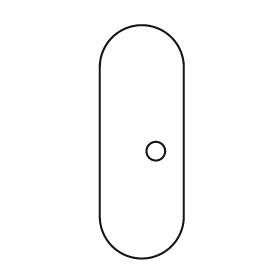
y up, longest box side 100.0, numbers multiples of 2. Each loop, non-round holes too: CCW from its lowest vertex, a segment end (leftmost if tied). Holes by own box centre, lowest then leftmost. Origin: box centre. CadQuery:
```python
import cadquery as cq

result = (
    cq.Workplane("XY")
    .moveTo(-18.0, -32.0)
    .threePointArc((0.0, -50.0), (18.0, -32.0))
    .lineTo(18.0, 32.0)
    .threePointArc((0.0, 50.0), (-18.0, 32.0))
    .close()
    .moveTo(6.0, -4.0)
    .circle(4.0)
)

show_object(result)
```